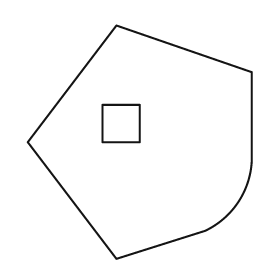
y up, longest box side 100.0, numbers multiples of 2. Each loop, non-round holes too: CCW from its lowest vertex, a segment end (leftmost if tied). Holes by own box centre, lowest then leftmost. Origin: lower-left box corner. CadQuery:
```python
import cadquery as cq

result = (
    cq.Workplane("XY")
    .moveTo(38.0, 0.0)
    .lineTo(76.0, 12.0)
    .threePointArc((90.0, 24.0), (96.0, 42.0))
    .lineTo(96.0, 80.0)
    .lineTo(38.0, 100.0)
    .lineTo(0.0, 50.0)
    .close()
    .moveTo(32.0, 50.0)
    .lineTo(48.0, 50.0)
    .lineTo(48.0, 66.0)
    .lineTo(32.0, 66.0)
    .close()
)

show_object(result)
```